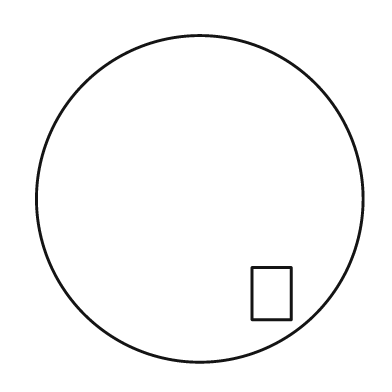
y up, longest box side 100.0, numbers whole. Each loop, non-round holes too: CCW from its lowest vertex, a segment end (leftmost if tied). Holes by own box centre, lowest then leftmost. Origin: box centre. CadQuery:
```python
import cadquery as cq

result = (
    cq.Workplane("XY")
    .moveTo(0.0, 0.0)
    .circle(50.0)
    .moveTo(16.0, -37.0)
    .lineTo(28.0, -37.0)
    .lineTo(28.0, -21.0)
    .lineTo(16.0, -21.0)
    .close()
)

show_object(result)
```